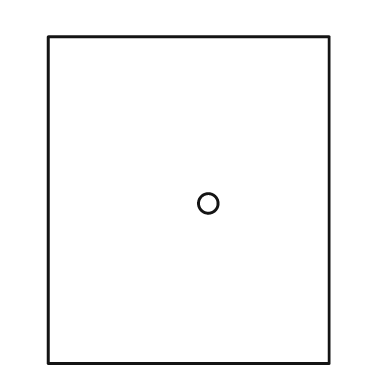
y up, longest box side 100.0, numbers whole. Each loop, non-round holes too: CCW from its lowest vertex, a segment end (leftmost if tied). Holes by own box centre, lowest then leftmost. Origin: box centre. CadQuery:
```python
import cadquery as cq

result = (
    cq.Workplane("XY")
    .moveTo(-43.0, -50.0)
    .lineTo(43.0, -50.0)
    .lineTo(43.0, 50.0)
    .lineTo(-43.0, 50.0)
    .close()
    .moveTo(6.0, -1.0)
    .circle(3.0)
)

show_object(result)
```